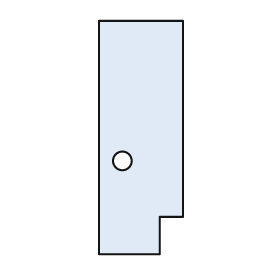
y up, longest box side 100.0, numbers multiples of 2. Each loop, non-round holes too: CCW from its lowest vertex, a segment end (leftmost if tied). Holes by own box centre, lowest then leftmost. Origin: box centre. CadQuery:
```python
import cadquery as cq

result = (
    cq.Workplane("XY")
    .moveTo(-18.0, -50.0)
    .lineTo(8.0, -50.0)
    .lineTo(8.0, -34.0)
    .lineTo(18.0, -34.0)
    .lineTo(18.0, 50.0)
    .lineTo(-18.0, 50.0)
    .close()
    .moveTo(-8.0, -10.0)
    .circle(4.0)
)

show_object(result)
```